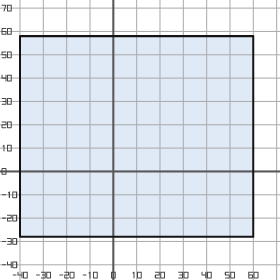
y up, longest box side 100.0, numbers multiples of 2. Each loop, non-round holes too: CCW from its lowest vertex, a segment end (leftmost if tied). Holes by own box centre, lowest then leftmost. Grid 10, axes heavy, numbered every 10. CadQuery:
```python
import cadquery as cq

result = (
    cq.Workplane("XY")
    .moveTo(-40.0, -28.0)
    .lineTo(60.0, -28.0)
    .lineTo(60.0, 58.0)
    .lineTo(-40.0, 58.0)
    .close()
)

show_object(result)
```